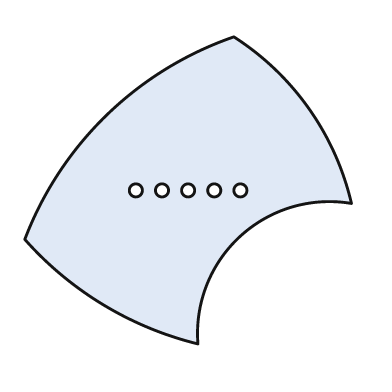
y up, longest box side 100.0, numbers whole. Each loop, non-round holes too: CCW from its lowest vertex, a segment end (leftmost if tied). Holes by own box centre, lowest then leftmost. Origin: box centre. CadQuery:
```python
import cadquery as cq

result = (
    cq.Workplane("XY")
    .moveTo(3.0, -47.0)
    .threePointArc((16.0, -14.0), (50.0, -4.0))
    .threePointArc((37.0, 25.0), (14.0, 47.0))
    .threePointArc((-25.0, 23.0), (-50.0, -15.0))
    .threePointArc((-26.0, -35.0), (3.0, -47.0))
    .close()
    .moveTo(-16.0, 0.0)
    .circle(2.0)
    .moveTo(-8.0, 0.0)
    .circle(2.0)
    .moveTo(0.0, 0.0)
    .circle(2.0)
    .moveTo(8.0, 0.0)
    .circle(2.0)
    .moveTo(16.0, 0.0)
    .circle(2.0)
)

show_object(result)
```